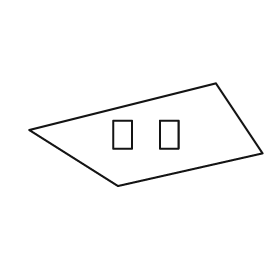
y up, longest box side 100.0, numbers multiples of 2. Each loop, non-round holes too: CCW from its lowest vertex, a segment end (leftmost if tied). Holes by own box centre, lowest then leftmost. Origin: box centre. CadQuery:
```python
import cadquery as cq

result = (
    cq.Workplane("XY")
    .moveTo(-12.0, -22.0)
    .lineTo(50.0, -8.0)
    .lineTo(30.0, 22.0)
    .lineTo(-50.0, 2.0)
    .close()
    .moveTo(-14.0, -6.0)
    .lineTo(-6.0, -6.0)
    .lineTo(-6.0, 6.0)
    .lineTo(-14.0, 6.0)
    .close()
    .moveTo(6.0, -6.0)
    .lineTo(14.0, -6.0)
    .lineTo(14.0, 6.0)
    .lineTo(6.0, 6.0)
    .close()
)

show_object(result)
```